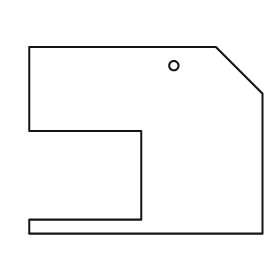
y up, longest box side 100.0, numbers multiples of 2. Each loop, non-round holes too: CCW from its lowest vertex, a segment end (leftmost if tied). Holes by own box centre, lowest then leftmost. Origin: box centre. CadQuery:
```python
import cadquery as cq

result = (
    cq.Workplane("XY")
    .moveTo(-50.0, -40.0)
    .lineTo(50.0, -40.0)
    .lineTo(50.0, 20.0)
    .lineTo(30.0, 40.0)
    .lineTo(-50.0, 40.0)
    .lineTo(-50.0, 4.0)
    .lineTo(-2.0, 4.0)
    .lineTo(-2.0, -34.0)
    .lineTo(-50.0, -34.0)
    .close()
    .moveTo(12.0, 32.0)
    .circle(2.0)
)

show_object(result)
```